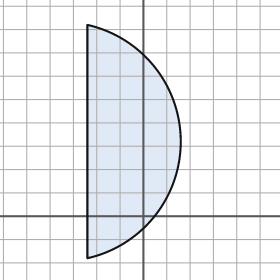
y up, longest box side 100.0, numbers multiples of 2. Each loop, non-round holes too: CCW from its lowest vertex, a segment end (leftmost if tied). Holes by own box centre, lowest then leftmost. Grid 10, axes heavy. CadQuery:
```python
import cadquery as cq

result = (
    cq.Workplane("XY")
    .moveTo(-24.0, -18.0)
    .threePointArc((16.0, 32.0), (-24.0, 82.0))
    .close()
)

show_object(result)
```